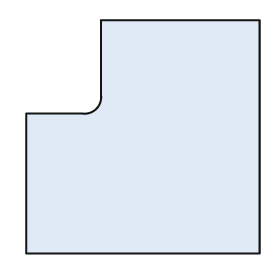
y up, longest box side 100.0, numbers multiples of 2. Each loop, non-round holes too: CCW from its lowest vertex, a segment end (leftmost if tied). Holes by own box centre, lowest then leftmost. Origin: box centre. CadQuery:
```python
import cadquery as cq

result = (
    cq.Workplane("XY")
    .moveTo(-50.0, -50.0)
    .lineTo(50.0, -50.0)
    .lineTo(50.0, 50.0)
    .lineTo(-18.0, 50.0)
    .lineTo(-18.0, 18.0)
    .threePointArc((-20.0, 12.0), (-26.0, 10.0))
    .lineTo(-50.0, 10.0)
    .close()
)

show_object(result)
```